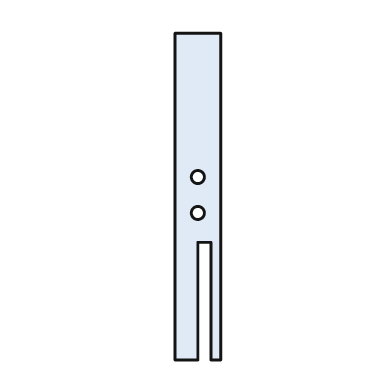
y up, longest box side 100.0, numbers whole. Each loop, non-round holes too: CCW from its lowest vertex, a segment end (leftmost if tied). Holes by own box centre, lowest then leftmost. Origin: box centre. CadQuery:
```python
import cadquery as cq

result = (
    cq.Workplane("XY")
    .moveTo(-7.0, -50.0)
    .lineTo(0.0, -50.0)
    .lineTo(0.0, -14.0)
    .lineTo(4.0, -14.0)
    .lineTo(4.0, -50.0)
    .lineTo(7.0, -50.0)
    .lineTo(7.0, 50.0)
    .lineTo(-7.0, 50.0)
    .close()
    .moveTo(0.0, -5.0)
    .circle(2.0)
    .moveTo(0.0, 6.0)
    .circle(2.0)
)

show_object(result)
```